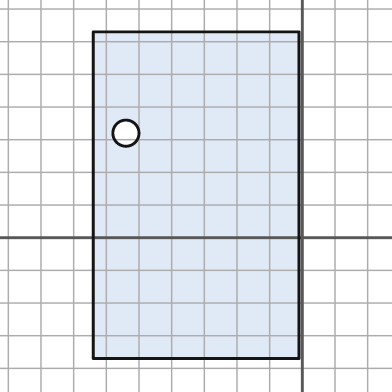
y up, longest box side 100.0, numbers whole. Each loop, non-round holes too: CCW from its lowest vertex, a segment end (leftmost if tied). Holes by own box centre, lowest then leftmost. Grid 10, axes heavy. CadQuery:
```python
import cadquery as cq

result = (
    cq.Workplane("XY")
    .moveTo(-64.0, -37.0)
    .lineTo(-1.0, -37.0)
    .lineTo(-1.0, 63.0)
    .lineTo(-64.0, 63.0)
    .close()
    .moveTo(-54.0, 32.0)
    .circle(4.0)
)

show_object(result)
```